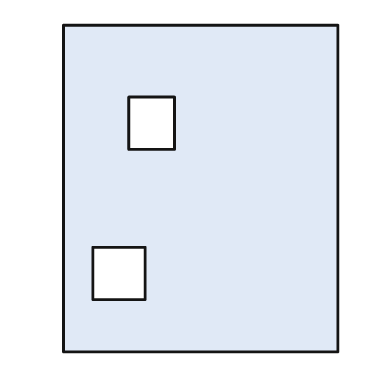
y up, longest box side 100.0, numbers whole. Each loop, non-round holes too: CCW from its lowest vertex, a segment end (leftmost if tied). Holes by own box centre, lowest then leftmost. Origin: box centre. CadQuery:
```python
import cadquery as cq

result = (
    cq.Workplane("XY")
    .moveTo(-42.0, -50.0)
    .lineTo(42.0, -50.0)
    .lineTo(42.0, 50.0)
    .lineTo(-42.0, 50.0)
    .close()
    .moveTo(-33.0, -34.0)
    .lineTo(-17.0, -34.0)
    .lineTo(-17.0, -18.0)
    .lineTo(-33.0, -18.0)
    .close()
    .moveTo(-22.0, 12.0)
    .lineTo(-8.0, 12.0)
    .lineTo(-8.0, 28.0)
    .lineTo(-22.0, 28.0)
    .close()
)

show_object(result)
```